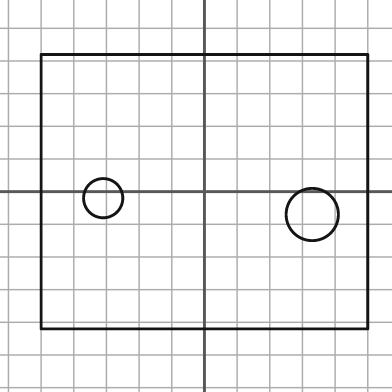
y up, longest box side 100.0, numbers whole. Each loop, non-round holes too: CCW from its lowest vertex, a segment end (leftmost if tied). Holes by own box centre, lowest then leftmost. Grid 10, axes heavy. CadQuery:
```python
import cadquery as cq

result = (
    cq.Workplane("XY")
    .moveTo(-50.0, -42.0)
    .lineTo(50.0, -42.0)
    .lineTo(50.0, 42.0)
    .lineTo(-50.0, 42.0)
    .close()
    .moveTo(33.0, -7.0)
    .circle(8.0)
    .moveTo(-31.0, -2.0)
    .circle(6.0)
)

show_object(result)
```